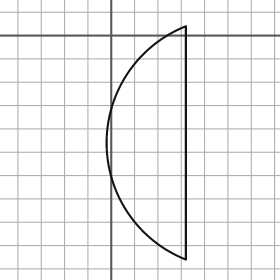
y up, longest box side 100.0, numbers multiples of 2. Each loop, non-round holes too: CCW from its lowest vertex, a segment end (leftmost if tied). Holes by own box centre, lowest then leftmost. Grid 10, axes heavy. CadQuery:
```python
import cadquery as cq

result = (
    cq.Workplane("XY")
    .moveTo(32.0, -96.0)
    .lineTo(32.0, 4.0)
    .threePointArc((-2.0, -46.0), (32.0, -96.0))
    .close()
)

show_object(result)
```